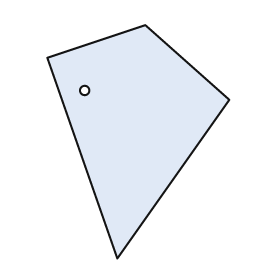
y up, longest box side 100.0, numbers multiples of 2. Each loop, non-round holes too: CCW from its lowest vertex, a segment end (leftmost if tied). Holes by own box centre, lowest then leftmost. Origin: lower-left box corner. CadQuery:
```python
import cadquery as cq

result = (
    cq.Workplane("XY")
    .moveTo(30.0, 0.0)
    .lineTo(78.0, 68.0)
    .lineTo(42.0, 100.0)
    .lineTo(0.0, 86.0)
    .close()
    .moveTo(16.0, 72.0)
    .circle(2.0)
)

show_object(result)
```